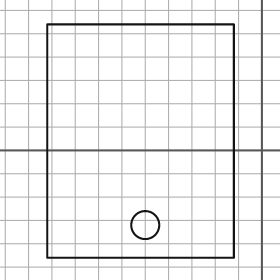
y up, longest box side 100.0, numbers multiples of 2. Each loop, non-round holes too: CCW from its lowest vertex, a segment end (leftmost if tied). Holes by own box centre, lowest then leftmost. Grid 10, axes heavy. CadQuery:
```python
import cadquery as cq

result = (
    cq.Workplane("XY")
    .moveTo(-92.0, -46.0)
    .lineTo(-12.0, -46.0)
    .lineTo(-12.0, 54.0)
    .lineTo(-92.0, 54.0)
    .close()
    .moveTo(-50.0, -32.0)
    .circle(6.0)
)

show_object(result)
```